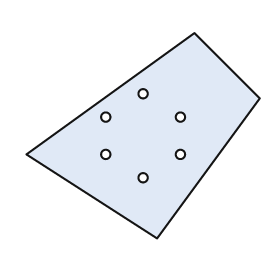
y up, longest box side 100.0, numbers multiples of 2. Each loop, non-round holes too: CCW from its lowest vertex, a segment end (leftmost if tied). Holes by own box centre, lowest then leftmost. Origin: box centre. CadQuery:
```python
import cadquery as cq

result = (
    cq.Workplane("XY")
    .moveTo(6.0, -44.0)
    .lineTo(50.0, 16.0)
    .lineTo(22.0, 44.0)
    .lineTo(-50.0, -8.0)
    .close()
    .moveTo(0.0, -18.0)
    .circle(2.0)
    .moveTo(-16.0, -8.0)
    .circle(2.0)
    .moveTo(16.0, -8.0)
    .circle(2.0)
    .moveTo(-16.0, 8.0)
    .circle(2.0)
    .moveTo(16.0, 8.0)
    .circle(2.0)
    .moveTo(0.0, 18.0)
    .circle(2.0)
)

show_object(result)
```